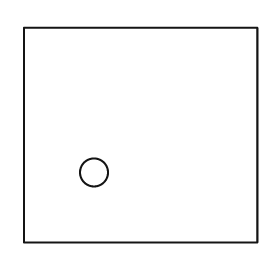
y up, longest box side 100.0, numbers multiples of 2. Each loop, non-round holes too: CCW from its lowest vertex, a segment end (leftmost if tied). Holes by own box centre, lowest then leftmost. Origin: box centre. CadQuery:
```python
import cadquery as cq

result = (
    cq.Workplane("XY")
    .moveTo(-50.0, -46.0)
    .lineTo(50.0, -46.0)
    .lineTo(50.0, 46.0)
    .lineTo(-50.0, 46.0)
    .close()
    .moveTo(-20.0, -16.0)
    .circle(6.0)
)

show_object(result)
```